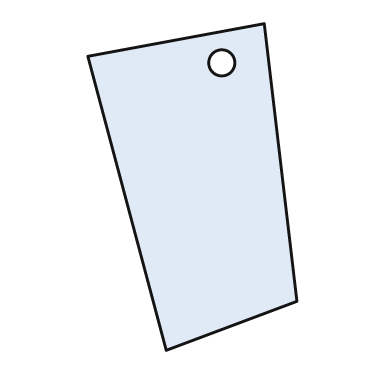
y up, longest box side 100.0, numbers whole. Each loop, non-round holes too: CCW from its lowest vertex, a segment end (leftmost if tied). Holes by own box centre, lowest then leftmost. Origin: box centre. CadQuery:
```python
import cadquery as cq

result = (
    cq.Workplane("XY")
    .moveTo(-8.0, -50.0)
    .lineTo(32.0, -35.0)
    .lineTo(22.0, 50.0)
    .lineTo(-32.0, 40.0)
    .close()
    .moveTo(9.0, 38.0)
    .circle(4.0)
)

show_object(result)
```